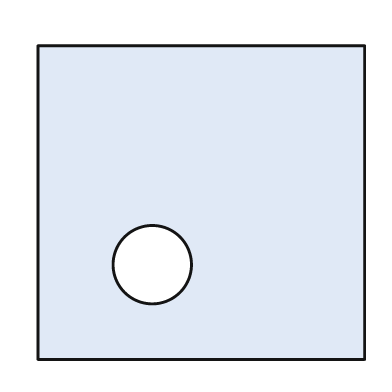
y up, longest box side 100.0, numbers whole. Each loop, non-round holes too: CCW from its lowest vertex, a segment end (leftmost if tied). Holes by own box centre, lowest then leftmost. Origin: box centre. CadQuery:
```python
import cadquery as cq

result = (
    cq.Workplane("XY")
    .moveTo(-50.0, -48.0)
    .lineTo(50.0, -48.0)
    .lineTo(50.0, 48.0)
    .lineTo(-50.0, 48.0)
    .close()
    .moveTo(-15.0, -19.0)
    .circle(12.0)
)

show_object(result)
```